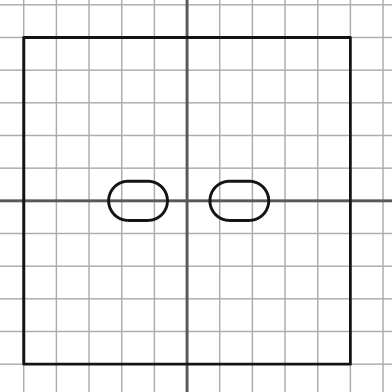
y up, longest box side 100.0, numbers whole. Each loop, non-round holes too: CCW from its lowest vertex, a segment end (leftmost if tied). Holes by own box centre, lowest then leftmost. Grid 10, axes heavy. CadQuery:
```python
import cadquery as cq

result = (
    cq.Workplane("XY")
    .moveTo(-50.0, -50.0)
    .lineTo(50.0, -50.0)
    .lineTo(50.0, 50.0)
    .lineTo(-50.0, 50.0)
    .close()
    .moveTo(-18.0, -6.0)
    .lineTo(-12.0, -6.0)
    .threePointArc((-6.0, 0.0), (-12.0, 6.0))
    .lineTo(-18.0, 6.0)
    .threePointArc((-24.0, 0.0), (-18.0, -6.0))
    .close()
    .moveTo(13.0, -6.0)
    .lineTo(19.0, -6.0)
    .threePointArc((25.0, 0.0), (19.0, 6.0))
    .lineTo(13.0, 6.0)
    .threePointArc((7.0, 0.0), (13.0, -6.0))
    .close()
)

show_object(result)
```